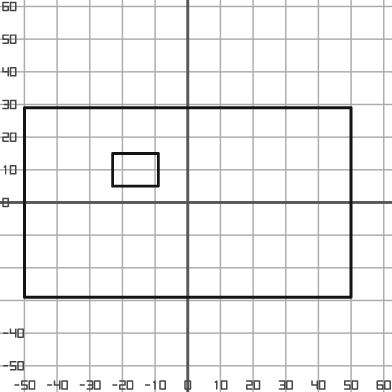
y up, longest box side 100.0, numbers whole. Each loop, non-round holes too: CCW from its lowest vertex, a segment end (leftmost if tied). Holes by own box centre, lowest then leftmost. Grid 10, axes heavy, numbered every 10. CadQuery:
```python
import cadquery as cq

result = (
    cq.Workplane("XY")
    .moveTo(-50.0, -29.0)
    .lineTo(50.0, -29.0)
    .lineTo(50.0, 29.0)
    .lineTo(-50.0, 29.0)
    .close()
    .moveTo(-23.0, 5.0)
    .lineTo(-9.0, 5.0)
    .lineTo(-9.0, 15.0)
    .lineTo(-23.0, 15.0)
    .close()
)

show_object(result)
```